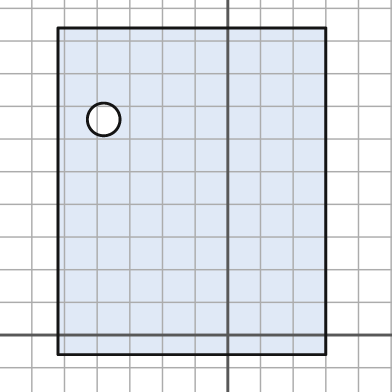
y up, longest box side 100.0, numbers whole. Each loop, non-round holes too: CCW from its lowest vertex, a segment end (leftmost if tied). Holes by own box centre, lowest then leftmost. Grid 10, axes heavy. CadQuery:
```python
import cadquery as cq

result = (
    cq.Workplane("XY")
    .moveTo(-52.0, -6.0)
    .lineTo(30.0, -6.0)
    .lineTo(30.0, 94.0)
    .lineTo(-52.0, 94.0)
    .close()
    .moveTo(-38.0, 66.0)
    .circle(5.0)
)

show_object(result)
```